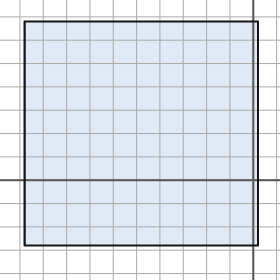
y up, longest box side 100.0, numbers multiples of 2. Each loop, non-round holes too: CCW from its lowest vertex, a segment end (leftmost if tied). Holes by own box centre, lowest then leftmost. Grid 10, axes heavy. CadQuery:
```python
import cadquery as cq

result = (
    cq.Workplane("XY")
    .moveTo(-98.0, -28.0)
    .lineTo(2.0, -28.0)
    .lineTo(2.0, 68.0)
    .lineTo(-98.0, 68.0)
    .close()
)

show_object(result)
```